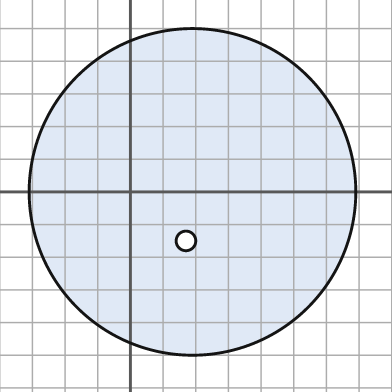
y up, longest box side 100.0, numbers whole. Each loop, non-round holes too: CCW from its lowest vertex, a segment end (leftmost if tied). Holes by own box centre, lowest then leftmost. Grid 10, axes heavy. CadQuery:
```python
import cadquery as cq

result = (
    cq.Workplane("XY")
    .moveTo(19.0, 0.0)
    .circle(50.0)
    .moveTo(17.0, -15.0)
    .circle(3.0)
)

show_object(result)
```